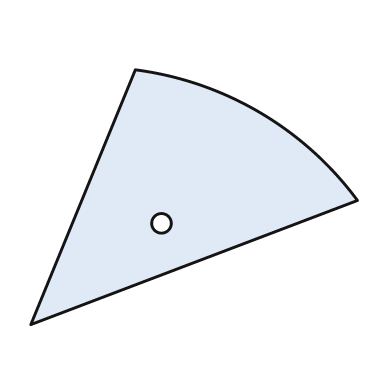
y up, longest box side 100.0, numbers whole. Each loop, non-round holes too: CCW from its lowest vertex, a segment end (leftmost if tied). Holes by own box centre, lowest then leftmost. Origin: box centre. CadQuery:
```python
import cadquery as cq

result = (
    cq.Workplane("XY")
    .moveTo(-50.0, -39.0)
    .lineTo(50.0, -1.0)
    .threePointArc((20.0, 26.0), (-18.0, 39.0))
    .close()
    .moveTo(-10.0, -8.0)
    .circle(3.0)
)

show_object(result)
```